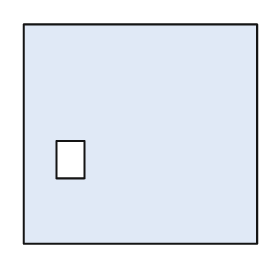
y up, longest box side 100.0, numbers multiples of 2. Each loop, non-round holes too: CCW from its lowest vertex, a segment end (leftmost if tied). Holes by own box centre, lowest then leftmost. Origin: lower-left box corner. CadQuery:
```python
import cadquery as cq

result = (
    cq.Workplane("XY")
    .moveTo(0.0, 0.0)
    .lineTo(100.0, 0.0)
    .lineTo(100.0, 94.0)
    .lineTo(0.0, 94.0)
    .close()
    .moveTo(14.0, 28.0)
    .lineTo(26.0, 28.0)
    .lineTo(26.0, 44.0)
    .lineTo(14.0, 44.0)
    .close()
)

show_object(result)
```